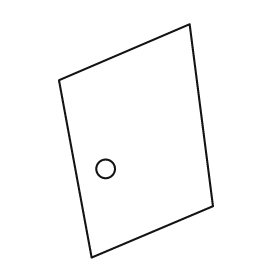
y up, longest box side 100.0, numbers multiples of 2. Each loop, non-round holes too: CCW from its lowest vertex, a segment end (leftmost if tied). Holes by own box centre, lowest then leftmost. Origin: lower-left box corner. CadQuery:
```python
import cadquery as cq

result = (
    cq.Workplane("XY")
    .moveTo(14.0, 0.0)
    .lineTo(66.0, 22.0)
    .lineTo(56.0, 100.0)
    .lineTo(0.0, 76.0)
    .close()
    .moveTo(20.0, 38.0)
    .circle(4.0)
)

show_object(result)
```